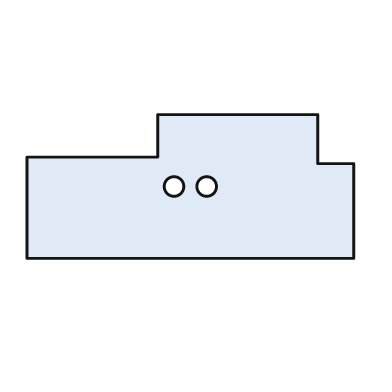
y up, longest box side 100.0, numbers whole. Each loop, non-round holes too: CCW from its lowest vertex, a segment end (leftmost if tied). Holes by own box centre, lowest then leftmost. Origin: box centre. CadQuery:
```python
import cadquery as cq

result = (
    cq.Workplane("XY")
    .moveTo(-50.0, -22.0)
    .lineTo(50.0, -22.0)
    .lineTo(50.0, 7.0)
    .lineTo(39.0, 7.0)
    .lineTo(39.0, 22.0)
    .lineTo(-10.0, 22.0)
    .lineTo(-10.0, 9.0)
    .lineTo(-50.0, 9.0)
    .close()
    .moveTo(-5.0, 0.0)
    .circle(3.0)
    .moveTo(5.0, 0.0)
    .circle(3.0)
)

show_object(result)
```